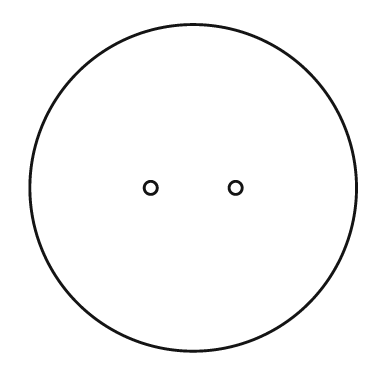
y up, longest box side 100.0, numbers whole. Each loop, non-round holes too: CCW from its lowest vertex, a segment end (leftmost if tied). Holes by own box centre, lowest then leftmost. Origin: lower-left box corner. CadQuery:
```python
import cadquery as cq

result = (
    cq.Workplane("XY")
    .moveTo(50.0, 50.0)
    .circle(50.0)
    .moveTo(37.0, 50.0)
    .circle(2.0)
    .moveTo(63.0, 50.0)
    .circle(2.0)
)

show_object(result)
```